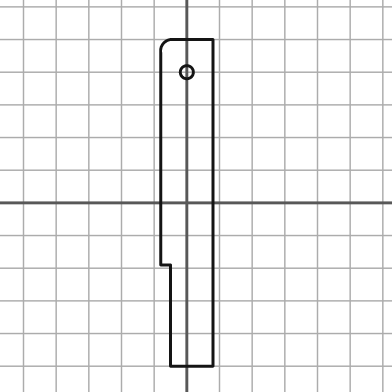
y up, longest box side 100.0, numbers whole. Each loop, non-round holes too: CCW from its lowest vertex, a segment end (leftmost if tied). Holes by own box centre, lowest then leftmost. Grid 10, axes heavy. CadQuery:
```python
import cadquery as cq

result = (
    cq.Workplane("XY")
    .moveTo(-5.0, -50.0)
    .lineTo(8.0, -50.0)
    .lineTo(8.0, 50.0)
    .lineTo(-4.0, 50.0)
    .threePointArc((-7.0, 49.0), (-8.0, 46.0))
    .lineTo(-8.0, -19.0)
    .lineTo(-5.0, -19.0)
    .close()
    .moveTo(0.0, 40.0)
    .circle(2.0)
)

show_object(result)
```